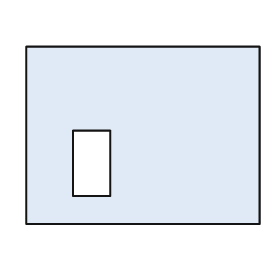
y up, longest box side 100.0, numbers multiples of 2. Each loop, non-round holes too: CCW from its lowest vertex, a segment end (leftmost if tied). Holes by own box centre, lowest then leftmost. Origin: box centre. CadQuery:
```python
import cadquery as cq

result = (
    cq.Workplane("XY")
    .moveTo(-50.0, -38.0)
    .lineTo(50.0, -38.0)
    .lineTo(50.0, 38.0)
    .lineTo(-50.0, 38.0)
    .close()
    .moveTo(-30.0, -26.0)
    .lineTo(-14.0, -26.0)
    .lineTo(-14.0, 2.0)
    .lineTo(-30.0, 2.0)
    .close()
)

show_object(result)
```